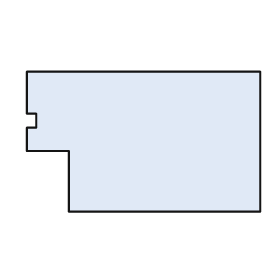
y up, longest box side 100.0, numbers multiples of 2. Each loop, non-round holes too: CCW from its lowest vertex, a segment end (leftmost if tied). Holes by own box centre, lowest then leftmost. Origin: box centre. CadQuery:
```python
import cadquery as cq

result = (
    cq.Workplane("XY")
    .moveTo(-32.0, -30.0)
    .lineTo(50.0, -30.0)
    .lineTo(50.0, 30.0)
    .lineTo(-50.0, 30.0)
    .lineTo(-50.0, 12.0)
    .lineTo(-46.0, 12.0)
    .lineTo(-46.0, 6.0)
    .lineTo(-50.0, 6.0)
    .lineTo(-50.0, -4.0)
    .lineTo(-32.0, -4.0)
    .close()
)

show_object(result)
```